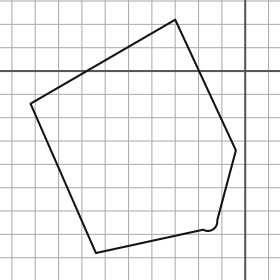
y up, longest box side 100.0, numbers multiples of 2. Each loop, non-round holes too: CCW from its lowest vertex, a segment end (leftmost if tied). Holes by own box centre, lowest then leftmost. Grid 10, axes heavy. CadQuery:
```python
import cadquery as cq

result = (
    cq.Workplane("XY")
    .moveTo(-64.0, -78.0)
    .lineTo(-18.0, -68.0)
    .threePointArc((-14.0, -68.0), (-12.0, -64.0))
    .lineTo(-4.0, -34.0)
    .lineTo(-30.0, 22.0)
    .lineTo(-92.0, -14.0)
    .close()
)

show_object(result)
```